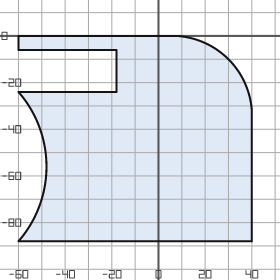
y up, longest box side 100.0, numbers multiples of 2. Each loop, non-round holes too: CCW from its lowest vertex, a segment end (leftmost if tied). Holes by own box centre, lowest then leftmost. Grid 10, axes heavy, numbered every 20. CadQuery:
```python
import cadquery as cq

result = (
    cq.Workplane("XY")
    .moveTo(-60.0, -88.0)
    .lineTo(40.0, -88.0)
    .lineTo(40.0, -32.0)
    .threePointArc((30.0, -10.0), (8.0, 0.0))
    .lineTo(-60.0, 0.0)
    .lineTo(-60.0, -6.0)
    .lineTo(-18.0, -6.0)
    .lineTo(-18.0, -24.0)
    .lineTo(-60.0, -24.0)
    .threePointArc((-48.0, -56.0), (-60.0, -88.0))
    .close()
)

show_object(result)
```